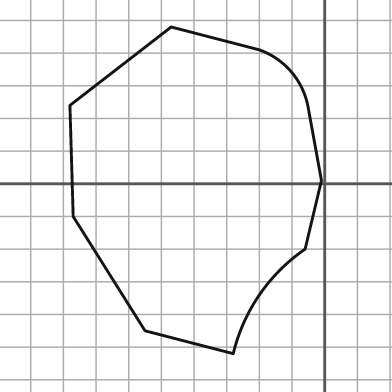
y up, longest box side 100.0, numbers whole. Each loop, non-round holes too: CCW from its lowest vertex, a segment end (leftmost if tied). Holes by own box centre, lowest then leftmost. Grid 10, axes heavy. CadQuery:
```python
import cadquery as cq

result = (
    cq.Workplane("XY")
    .moveTo(-28.0, -52.0)
    .threePointArc((-20.0, -34.0), (-6.0, -20.0))
    .lineTo(-1.0, 1.0)
    .lineTo(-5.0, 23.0)
    .threePointArc((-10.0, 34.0), (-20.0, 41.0))
    .lineTo(-47.0, 48.0)
    .lineTo(-78.0, 24.0)
    .lineTo(-77.0, -10.0)
    .lineTo(-55.0, -45.0)
    .close()
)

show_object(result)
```